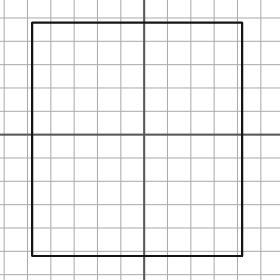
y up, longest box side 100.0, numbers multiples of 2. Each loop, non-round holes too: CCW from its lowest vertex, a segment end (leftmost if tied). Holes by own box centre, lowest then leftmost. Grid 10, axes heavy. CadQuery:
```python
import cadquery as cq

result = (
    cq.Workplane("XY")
    .moveTo(-48.0, -52.0)
    .lineTo(42.0, -52.0)
    .lineTo(42.0, 48.0)
    .lineTo(-48.0, 48.0)
    .close()
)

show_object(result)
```